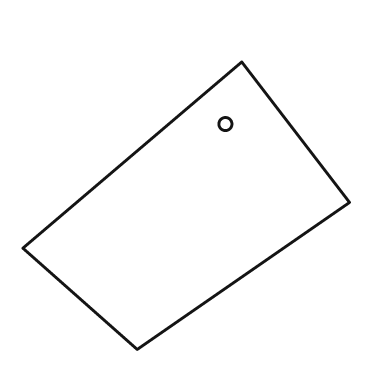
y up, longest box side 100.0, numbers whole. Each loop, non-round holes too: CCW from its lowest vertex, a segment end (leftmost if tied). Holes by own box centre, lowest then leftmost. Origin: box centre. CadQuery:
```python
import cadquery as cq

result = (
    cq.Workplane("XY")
    .moveTo(-15.0, -44.0)
    .lineTo(50.0, 1.0)
    .lineTo(17.0, 44.0)
    .lineTo(-50.0, -13.0)
    .close()
    .moveTo(12.0, 25.0)
    .circle(2.0)
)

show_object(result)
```